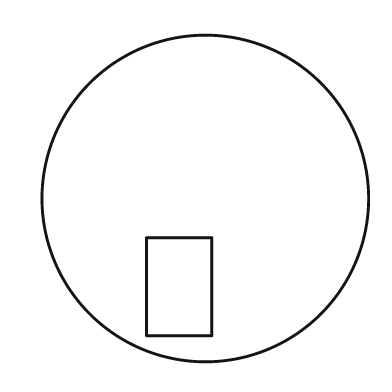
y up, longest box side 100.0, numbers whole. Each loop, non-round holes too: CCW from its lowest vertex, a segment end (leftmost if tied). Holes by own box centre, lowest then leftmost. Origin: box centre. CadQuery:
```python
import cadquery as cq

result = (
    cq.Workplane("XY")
    .moveTo(0.0, 0.0)
    .circle(50.0)
    .moveTo(-18.0, -42.0)
    .lineTo(2.0, -42.0)
    .lineTo(2.0, -12.0)
    .lineTo(-18.0, -12.0)
    .close()
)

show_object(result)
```